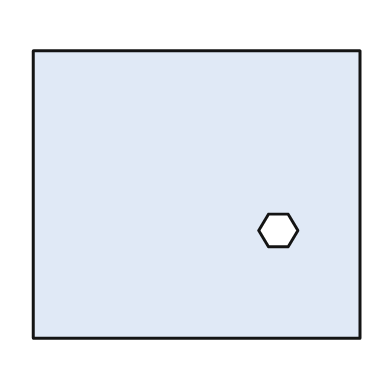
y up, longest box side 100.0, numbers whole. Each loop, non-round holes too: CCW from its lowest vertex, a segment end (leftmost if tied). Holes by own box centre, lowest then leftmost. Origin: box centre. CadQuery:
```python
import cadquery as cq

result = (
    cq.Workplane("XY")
    .moveTo(-50.0, -44.0)
    .lineTo(50.0, -44.0)
    .lineTo(50.0, 44.0)
    .lineTo(-50.0, 44.0)
    .close()
    .moveTo(22.0, -16.0)
    .lineTo(28.0, -16.0)
    .lineTo(31.0, -11.0)
    .lineTo(28.0, -6.0)
    .lineTo(22.0, -6.0)
    .lineTo(19.0, -11.0)
    .close()
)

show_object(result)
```